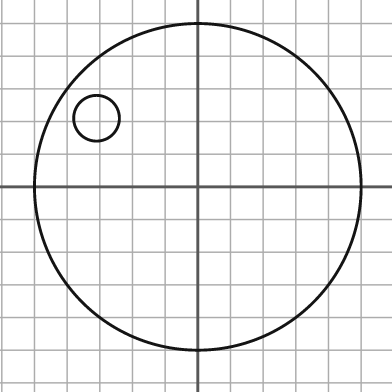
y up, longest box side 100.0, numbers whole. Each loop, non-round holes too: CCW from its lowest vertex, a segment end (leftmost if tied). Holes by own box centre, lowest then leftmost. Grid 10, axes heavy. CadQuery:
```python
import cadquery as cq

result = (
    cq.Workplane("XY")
    .moveTo(0.0, 0.0)
    .circle(50.0)
    .moveTo(-31.0, 21.0)
    .circle(7.0)
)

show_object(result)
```